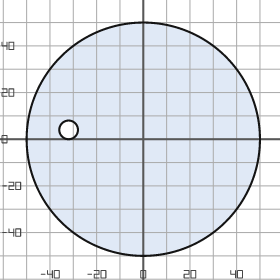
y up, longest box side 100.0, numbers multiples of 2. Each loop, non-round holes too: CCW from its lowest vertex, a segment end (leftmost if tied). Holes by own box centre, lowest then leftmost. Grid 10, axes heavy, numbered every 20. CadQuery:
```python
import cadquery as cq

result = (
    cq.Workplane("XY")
    .moveTo(0.0, 0.0)
    .circle(50.0)
    .moveTo(-32.0, 4.0)
    .circle(4.0)
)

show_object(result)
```